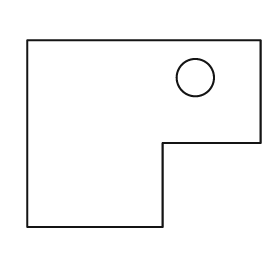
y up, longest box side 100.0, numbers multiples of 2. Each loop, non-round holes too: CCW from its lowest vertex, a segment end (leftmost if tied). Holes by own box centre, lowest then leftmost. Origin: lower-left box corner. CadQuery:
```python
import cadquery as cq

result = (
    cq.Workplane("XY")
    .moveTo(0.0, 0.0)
    .lineTo(58.0, 0.0)
    .lineTo(58.0, 36.0)
    .lineTo(100.0, 36.0)
    .lineTo(100.0, 80.0)
    .lineTo(0.0, 80.0)
    .close()
    .moveTo(72.0, 64.0)
    .circle(8.0)
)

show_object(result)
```